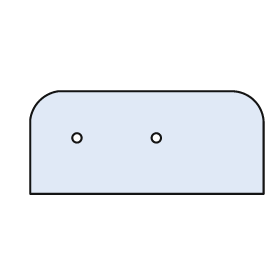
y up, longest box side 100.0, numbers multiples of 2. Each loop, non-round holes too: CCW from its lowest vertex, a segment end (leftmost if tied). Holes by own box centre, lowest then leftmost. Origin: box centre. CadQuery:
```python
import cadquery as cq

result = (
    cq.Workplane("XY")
    .moveTo(-50.0, -22.0)
    .lineTo(50.0, -22.0)
    .lineTo(50.0, 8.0)
    .threePointArc((46.0, 18.0), (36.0, 22.0))
    .lineTo(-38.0, 22.0)
    .threePointArc((-46.0, 18.0), (-50.0, 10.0))
    .close()
    .moveTo(-30.0, 2.0)
    .circle(2.0)
    .moveTo(4.0, 2.0)
    .circle(2.0)
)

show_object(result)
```